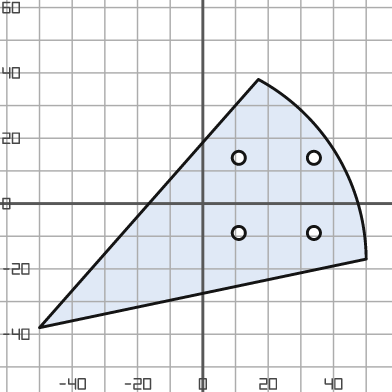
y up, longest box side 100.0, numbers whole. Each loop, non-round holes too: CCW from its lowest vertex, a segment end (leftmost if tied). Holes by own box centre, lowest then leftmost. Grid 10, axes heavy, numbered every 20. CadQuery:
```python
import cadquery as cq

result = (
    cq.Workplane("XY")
    .moveTo(-50.0, -38.0)
    .lineTo(50.0, -17.0)
    .threePointArc((41.0, 15.0), (17.0, 38.0))
    .close()
    .moveTo(11.0, -9.0)
    .circle(2.0)
    .moveTo(34.0, -9.0)
    .circle(2.0)
    .moveTo(11.0, 14.0)
    .circle(2.0)
    .moveTo(34.0, 14.0)
    .circle(2.0)
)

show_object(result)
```